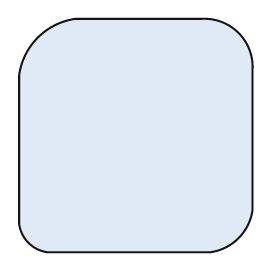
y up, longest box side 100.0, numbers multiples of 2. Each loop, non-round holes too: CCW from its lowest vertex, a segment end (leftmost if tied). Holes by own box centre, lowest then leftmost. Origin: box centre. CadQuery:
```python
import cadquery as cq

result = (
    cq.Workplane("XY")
    .moveTo(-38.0, -50.0)
    .lineTo(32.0, -50.0)
    .threePointArc((44.0, -44.0), (50.0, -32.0))
    .lineTo(50.0, 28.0)
    .threePointArc((44.0, 44.0), (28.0, 50.0))
    .lineTo(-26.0, 50.0)
    .threePointArc((-42.0, 42.0), (-50.0, 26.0))
    .lineTo(-50.0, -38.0)
    .threePointArc((-46.0, -46.0), (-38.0, -50.0))
    .close()
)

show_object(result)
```